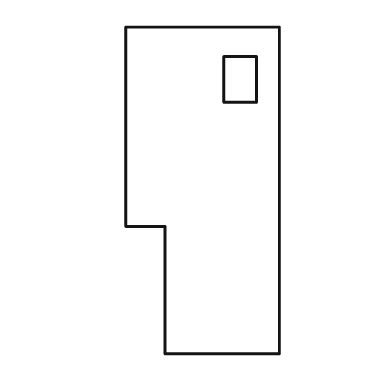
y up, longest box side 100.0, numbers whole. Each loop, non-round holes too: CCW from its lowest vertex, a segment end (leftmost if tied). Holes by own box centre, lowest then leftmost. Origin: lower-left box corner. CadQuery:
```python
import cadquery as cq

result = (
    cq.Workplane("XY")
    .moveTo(12.0, 0.0)
    .lineTo(47.0, 0.0)
    .lineTo(47.0, 100.0)
    .lineTo(0.0, 100.0)
    .lineTo(0.0, 39.0)
    .lineTo(12.0, 39.0)
    .close()
    .moveTo(30.0, 77.0)
    .lineTo(40.0, 77.0)
    .lineTo(40.0, 91.0)
    .lineTo(30.0, 91.0)
    .close()
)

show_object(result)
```